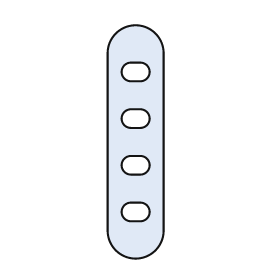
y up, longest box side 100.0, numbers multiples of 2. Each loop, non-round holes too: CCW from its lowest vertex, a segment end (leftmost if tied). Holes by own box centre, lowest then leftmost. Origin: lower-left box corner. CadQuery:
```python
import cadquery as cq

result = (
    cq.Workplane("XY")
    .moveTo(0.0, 12.0)
    .threePointArc((12.0, 0.0), (24.0, 12.0))
    .lineTo(24.0, 88.0)
    .threePointArc((12.0, 100.0), (0.0, 88.0))
    .close()
    .moveTo(10.0, 16.0)
    .lineTo(14.0, 16.0)
    .threePointArc((18.0, 20.0), (14.0, 24.0))
    .lineTo(10.0, 24.0)
    .threePointArc((6.0, 20.0), (10.0, 16.0))
    .close()
    .moveTo(10.0, 36.0)
    .lineTo(14.0, 36.0)
    .threePointArc((18.0, 40.0), (14.0, 44.0))
    .lineTo(10.0, 44.0)
    .threePointArc((6.0, 40.0), (10.0, 36.0))
    .close()
    .moveTo(10.0, 56.0)
    .lineTo(14.0, 56.0)
    .threePointArc((18.0, 60.0), (14.0, 64.0))
    .lineTo(10.0, 64.0)
    .threePointArc((6.0, 60.0), (10.0, 56.0))
    .close()
    .moveTo(10.0, 76.0)
    .lineTo(14.0, 76.0)
    .threePointArc((18.0, 80.0), (14.0, 84.0))
    .lineTo(10.0, 84.0)
    .threePointArc((6.0, 80.0), (10.0, 76.0))
    .close()
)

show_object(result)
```